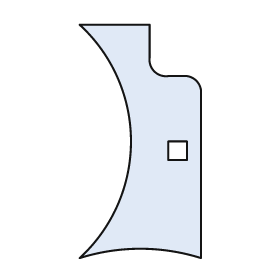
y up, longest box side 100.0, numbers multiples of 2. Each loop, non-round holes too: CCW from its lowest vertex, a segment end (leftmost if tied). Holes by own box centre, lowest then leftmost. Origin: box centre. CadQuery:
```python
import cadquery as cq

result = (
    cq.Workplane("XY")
    .moveTo(-26.0, -50.0)
    .threePointArc((0.0, -46.0), (26.0, -50.0))
    .lineTo(26.0, 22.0)
    .threePointArc((24.0, 26.0), (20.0, 28.0))
    .lineTo(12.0, 28.0)
    .threePointArc((6.0, 30.0), (4.0, 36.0))
    .lineTo(4.0, 50.0)
    .lineTo(-26.0, 50.0)
    .threePointArc((-4.0, 0.0), (-26.0, -50.0))
    .close()
    .moveTo(12.0, -8.0)
    .lineTo(20.0, -8.0)
    .lineTo(20.0, 0.0)
    .lineTo(12.0, 0.0)
    .close()
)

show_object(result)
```